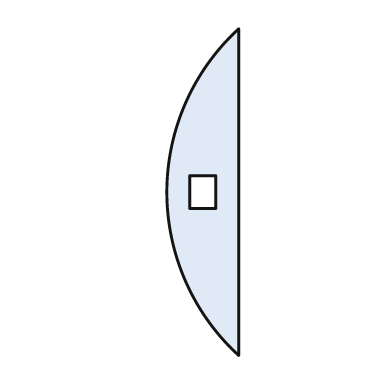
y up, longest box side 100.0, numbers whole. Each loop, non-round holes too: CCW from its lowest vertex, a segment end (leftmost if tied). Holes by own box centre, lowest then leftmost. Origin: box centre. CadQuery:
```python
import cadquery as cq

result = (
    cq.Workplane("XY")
    .moveTo(11.0, -50.0)
    .lineTo(11.0, 50.0)
    .threePointArc((-11.0, 0.0), (11.0, -50.0))
    .close()
    .moveTo(-4.0, -5.0)
    .lineTo(4.0, -5.0)
    .lineTo(4.0, 5.0)
    .lineTo(-4.0, 5.0)
    .close()
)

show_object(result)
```